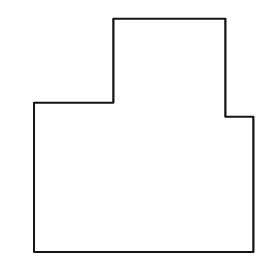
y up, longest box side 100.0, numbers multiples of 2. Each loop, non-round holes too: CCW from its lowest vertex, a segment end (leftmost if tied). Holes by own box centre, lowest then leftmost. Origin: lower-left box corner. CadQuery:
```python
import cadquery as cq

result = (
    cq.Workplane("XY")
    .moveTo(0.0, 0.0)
    .lineTo(94.0, 0.0)
    .lineTo(94.0, 58.0)
    .lineTo(82.0, 58.0)
    .lineTo(82.0, 100.0)
    .lineTo(34.0, 100.0)
    .lineTo(34.0, 64.0)
    .lineTo(0.0, 64.0)
    .close()
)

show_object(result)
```